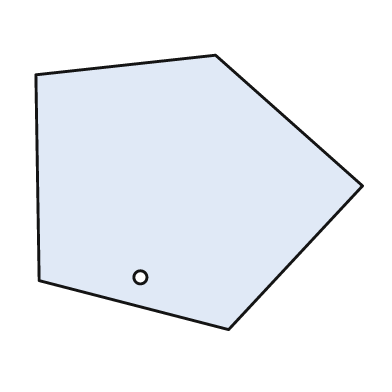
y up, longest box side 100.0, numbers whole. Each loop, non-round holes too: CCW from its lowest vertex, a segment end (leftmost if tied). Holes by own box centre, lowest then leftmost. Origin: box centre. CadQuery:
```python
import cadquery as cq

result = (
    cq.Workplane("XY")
    .moveTo(9.0, -42.0)
    .lineTo(50.0, 2.0)
    .lineTo(5.0, 42.0)
    .lineTo(-50.0, 36.0)
    .lineTo(-49.0, -27.0)
    .close()
    .moveTo(-18.0, -26.0)
    .circle(2.0)
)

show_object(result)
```